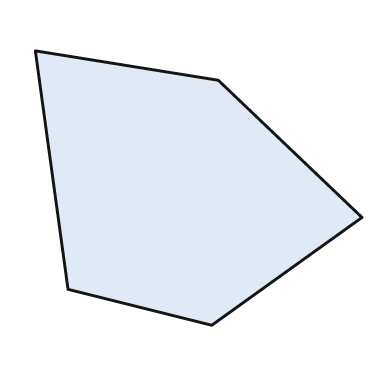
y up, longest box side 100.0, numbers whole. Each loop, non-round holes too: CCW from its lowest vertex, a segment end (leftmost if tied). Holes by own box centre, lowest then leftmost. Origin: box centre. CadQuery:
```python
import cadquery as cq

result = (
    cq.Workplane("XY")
    .moveTo(4.0, -42.0)
    .lineTo(50.0, -9.0)
    .lineTo(6.0, 33.0)
    .lineTo(-50.0, 42.0)
    .lineTo(-40.0, -31.0)
    .close()
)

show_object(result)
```